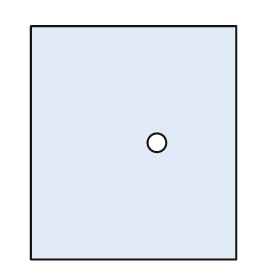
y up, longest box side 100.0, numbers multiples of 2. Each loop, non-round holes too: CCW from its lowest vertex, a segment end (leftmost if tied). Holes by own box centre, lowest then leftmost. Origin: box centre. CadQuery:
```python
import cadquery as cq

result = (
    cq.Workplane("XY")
    .moveTo(-44.0, -50.0)
    .lineTo(44.0, -50.0)
    .lineTo(44.0, 50.0)
    .lineTo(-44.0, 50.0)
    .close()
    .moveTo(10.0, 0.0)
    .circle(4.0)
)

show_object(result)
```